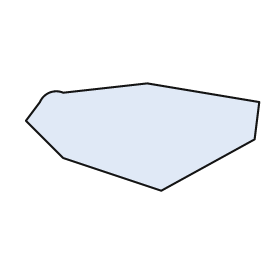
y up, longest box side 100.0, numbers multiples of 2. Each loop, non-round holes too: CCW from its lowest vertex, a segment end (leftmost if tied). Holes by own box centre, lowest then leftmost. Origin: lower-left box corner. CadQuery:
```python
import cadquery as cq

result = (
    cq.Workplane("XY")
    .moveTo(58.0, 0.0)
    .lineTo(98.0, 22.0)
    .lineTo(100.0, 38.0)
    .lineTo(52.0, 46.0)
    .lineTo(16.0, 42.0)
    .threePointArc((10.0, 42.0), (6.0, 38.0))
    .lineTo(0.0, 30.0)
    .lineTo(16.0, 14.0)
    .close()
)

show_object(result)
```